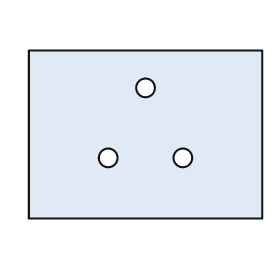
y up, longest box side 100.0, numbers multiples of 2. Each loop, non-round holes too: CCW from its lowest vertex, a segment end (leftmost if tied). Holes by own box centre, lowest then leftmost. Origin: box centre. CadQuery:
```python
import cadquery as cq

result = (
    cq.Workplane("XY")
    .moveTo(-50.0, -36.0)
    .lineTo(50.0, -36.0)
    .lineTo(50.0, 36.0)
    .lineTo(-50.0, 36.0)
    .close()
    .moveTo(-16.0, -10.0)
    .circle(4.0)
    .moveTo(16.0, -10.0)
    .circle(4.0)
    .moveTo(0.0, 20.0)
    .circle(4.0)
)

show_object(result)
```